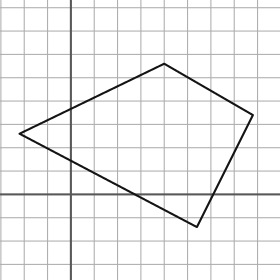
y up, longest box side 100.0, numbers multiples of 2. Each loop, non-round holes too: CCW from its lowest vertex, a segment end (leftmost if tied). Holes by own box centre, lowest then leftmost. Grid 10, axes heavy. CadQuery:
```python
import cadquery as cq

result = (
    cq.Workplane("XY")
    .moveTo(54.0, -14.0)
    .lineTo(78.0, 34.0)
    .lineTo(40.0, 56.0)
    .lineTo(-22.0, 26.0)
    .close()
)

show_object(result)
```